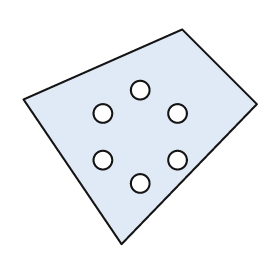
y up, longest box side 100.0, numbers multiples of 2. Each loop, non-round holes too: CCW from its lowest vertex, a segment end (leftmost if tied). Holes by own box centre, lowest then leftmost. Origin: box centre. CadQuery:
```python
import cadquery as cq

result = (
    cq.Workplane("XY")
    .moveTo(-8.0, -46.0)
    .lineTo(50.0, 14.0)
    .lineTo(18.0, 46.0)
    .lineTo(-50.0, 16.0)
    .close()
    .moveTo(0.0, -20.0)
    .circle(4.0)
    .moveTo(-16.0, -10.0)
    .circle(4.0)
    .moveTo(16.0, -10.0)
    .circle(4.0)
    .moveTo(-16.0, 10.0)
    .circle(4.0)
    .moveTo(16.0, 10.0)
    .circle(4.0)
    .moveTo(0.0, 20.0)
    .circle(4.0)
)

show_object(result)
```